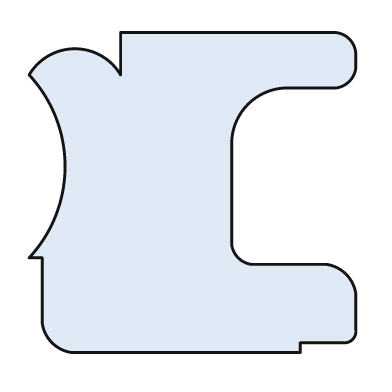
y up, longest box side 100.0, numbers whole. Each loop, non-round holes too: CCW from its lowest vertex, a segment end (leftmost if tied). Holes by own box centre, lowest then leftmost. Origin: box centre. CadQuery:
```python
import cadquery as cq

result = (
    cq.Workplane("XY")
    .moveTo(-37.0, -49.0)
    .lineTo(33.0, -49.0)
    .lineTo(33.0, -46.0)
    .lineTo(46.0, -46.0)
    .threePointArc((49.0, -45.0), (50.0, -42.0))
    .lineTo(50.0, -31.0)
    .threePointArc((47.0, -25.0), (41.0, -22.0))
    .lineTo(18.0, -22.0)
    .threePointArc((14.0, -20.0), (12.0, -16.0))
    .lineTo(12.0, 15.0)
    .threePointArc((17.0, 27.0), (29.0, 32.0))
    .lineTo(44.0, 32.0)
    .threePointArc((48.0, 34.0), (50.0, 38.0))
    .lineTo(50.0, 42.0)
    .threePointArc((48.0, 47.0), (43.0, 49.0))
    .lineTo(-22.0, 49.0)
    .lineTo(-22.0, 36.0)
    .threePointArc((-36.0, 44.0), (-50.0, 36.0))
    .threePointArc((-39.0, 8.0), (-50.0, -20.0))
    .lineTo(-46.0, -20.0)
    .lineTo(-46.0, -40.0)
    .threePointArc((-43.0, -46.0), (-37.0, -49.0))
    .close()
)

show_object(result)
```